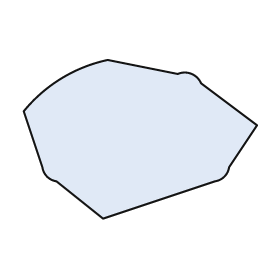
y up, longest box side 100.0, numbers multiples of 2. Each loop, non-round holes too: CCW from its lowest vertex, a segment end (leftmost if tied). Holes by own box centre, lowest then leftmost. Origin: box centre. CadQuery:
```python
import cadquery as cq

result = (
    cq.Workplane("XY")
    .moveTo(-16.0, -34.0)
    .lineTo(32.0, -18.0)
    .threePointArc((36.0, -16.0), (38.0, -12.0))
    .lineTo(50.0, 6.0)
    .lineTo(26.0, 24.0)
    .threePointArc((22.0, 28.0), (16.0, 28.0))
    .lineTo(-14.0, 34.0)
    .threePointArc((-34.0, 26.0), (-50.0, 12.0))
    .lineTo(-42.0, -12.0)
    .threePointArc((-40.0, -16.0), (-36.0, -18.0))
    .close()
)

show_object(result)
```